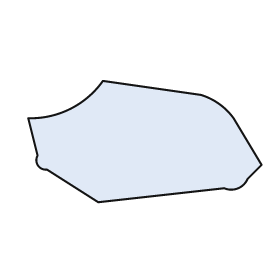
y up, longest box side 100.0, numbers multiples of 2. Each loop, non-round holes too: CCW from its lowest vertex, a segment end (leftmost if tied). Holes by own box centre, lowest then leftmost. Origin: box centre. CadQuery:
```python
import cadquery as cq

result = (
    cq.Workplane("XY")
    .moveTo(-20.0, -26.0)
    .lineTo(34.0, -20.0)
    .threePointArc((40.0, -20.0), (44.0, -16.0))
    .lineTo(50.0, -10.0)
    .lineTo(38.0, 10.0)
    .threePointArc((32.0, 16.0), (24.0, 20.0))
    .lineTo(-18.0, 26.0)
    .threePointArc((-32.0, 14.0), (-50.0, 10.0))
    .lineTo(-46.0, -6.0)
    .threePointArc((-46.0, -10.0), (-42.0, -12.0))
    .close()
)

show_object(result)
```